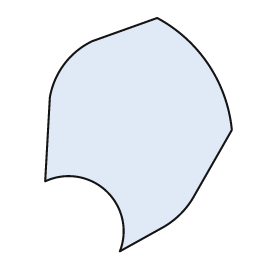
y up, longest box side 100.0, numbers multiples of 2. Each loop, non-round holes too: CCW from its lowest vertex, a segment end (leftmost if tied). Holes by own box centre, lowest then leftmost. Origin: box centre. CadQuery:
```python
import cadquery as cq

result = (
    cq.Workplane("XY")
    .moveTo(-8.0, -50.0)
    .lineTo(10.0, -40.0)
    .threePointArc((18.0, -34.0), (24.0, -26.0))
    .lineTo(40.0, 2.0)
    .threePointArc((30.0, 30.0), (8.0, 50.0))
    .lineTo(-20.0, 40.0)
    .threePointArc((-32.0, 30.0), (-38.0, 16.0))
    .lineTo(-40.0, -20.0)
    .threePointArc((-14.0, -24.0), (-8.0, -50.0))
    .close()
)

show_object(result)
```